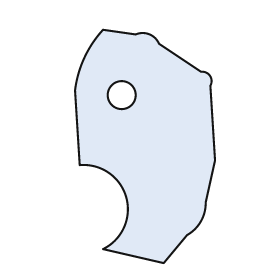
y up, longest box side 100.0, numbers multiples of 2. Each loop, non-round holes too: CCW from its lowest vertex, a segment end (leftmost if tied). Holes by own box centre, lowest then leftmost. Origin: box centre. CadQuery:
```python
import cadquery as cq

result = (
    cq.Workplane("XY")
    .moveTo(8.0, -50.0)
    .lineTo(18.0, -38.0)
    .threePointArc((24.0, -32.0), (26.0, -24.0))
    .lineTo(30.0, -6.0)
    .lineTo(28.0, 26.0)
    .threePointArc((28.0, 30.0), (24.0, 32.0))
    .lineTo(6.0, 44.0)
    .threePointArc((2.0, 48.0), (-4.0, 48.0))
    .lineTo(-18.0, 50.0)
    .threePointArc((-26.0, 38.0), (-30.0, 24.0))
    .lineTo(-28.0, -8.0)
    .threePointArc((-8.0, -22.0), (-18.0, -44.0))
    .close()
    .moveTo(-10.0, 22.0)
    .circle(6.0)
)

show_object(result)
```